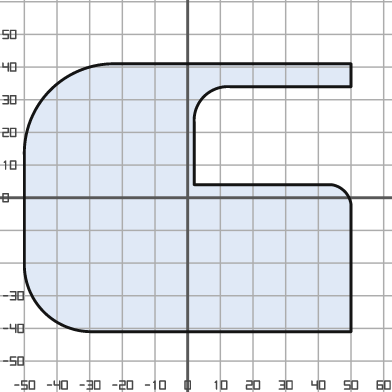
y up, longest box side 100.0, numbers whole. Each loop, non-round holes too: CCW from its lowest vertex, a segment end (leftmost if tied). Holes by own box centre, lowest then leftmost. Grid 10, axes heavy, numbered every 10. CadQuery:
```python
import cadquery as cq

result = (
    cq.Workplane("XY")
    .moveTo(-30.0, -41.0)
    .lineTo(50.0, -41.0)
    .lineTo(50.0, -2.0)
    .threePointArc((48.0, 2.0), (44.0, 4.0))
    .lineTo(2.0, 4.0)
    .lineTo(2.0, 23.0)
    .threePointArc((5.0, 31.0), (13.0, 34.0))
    .lineTo(50.0, 34.0)
    .lineTo(50.0, 41.0)
    .lineTo(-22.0, 41.0)
    .threePointArc((-42.0, 33.0), (-50.0, 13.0))
    .lineTo(-50.0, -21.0)
    .threePointArc((-44.0, -35.0), (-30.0, -41.0))
    .close()
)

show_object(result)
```